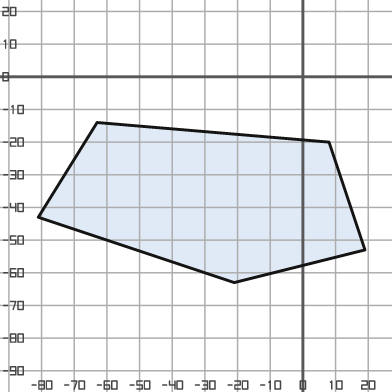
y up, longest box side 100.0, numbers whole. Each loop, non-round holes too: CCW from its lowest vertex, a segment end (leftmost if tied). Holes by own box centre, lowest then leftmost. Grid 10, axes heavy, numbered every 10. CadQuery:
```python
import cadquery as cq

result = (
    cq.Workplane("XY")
    .moveTo(-21.0, -63.0)
    .lineTo(19.0, -53.0)
    .lineTo(8.0, -20.0)
    .lineTo(-63.0, -14.0)
    .lineTo(-81.0, -43.0)
    .close()
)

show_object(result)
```